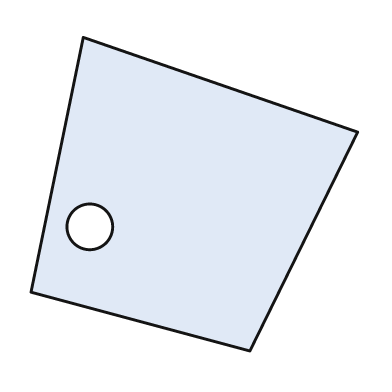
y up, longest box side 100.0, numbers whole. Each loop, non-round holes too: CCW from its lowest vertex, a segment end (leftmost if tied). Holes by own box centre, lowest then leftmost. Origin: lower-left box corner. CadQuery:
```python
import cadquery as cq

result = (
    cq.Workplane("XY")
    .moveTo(67.0, 0.0)
    .lineTo(100.0, 67.0)
    .lineTo(16.0, 96.0)
    .lineTo(0.0, 18.0)
    .close()
    .moveTo(18.0, 38.0)
    .circle(7.0)
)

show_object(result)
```